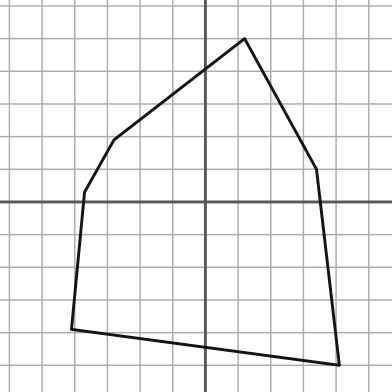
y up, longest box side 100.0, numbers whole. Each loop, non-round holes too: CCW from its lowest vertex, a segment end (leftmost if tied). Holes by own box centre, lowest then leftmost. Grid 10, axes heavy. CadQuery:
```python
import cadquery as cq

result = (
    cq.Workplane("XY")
    .moveTo(41.0, -50.0)
    .lineTo(34.0, 10.0)
    .lineTo(12.0, 50.0)
    .lineTo(-28.0, 19.0)
    .lineTo(-37.0, 3.0)
    .lineTo(-41.0, -39.0)
    .close()
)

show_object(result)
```